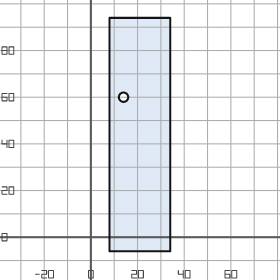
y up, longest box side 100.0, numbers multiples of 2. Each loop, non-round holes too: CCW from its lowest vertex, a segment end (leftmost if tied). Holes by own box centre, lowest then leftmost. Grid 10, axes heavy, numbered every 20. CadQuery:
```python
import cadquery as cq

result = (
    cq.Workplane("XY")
    .moveTo(8.0, -6.0)
    .lineTo(34.0, -6.0)
    .lineTo(34.0, 94.0)
    .lineTo(8.0, 94.0)
    .close()
    .moveTo(14.0, 60.0)
    .circle(2.0)
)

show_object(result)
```